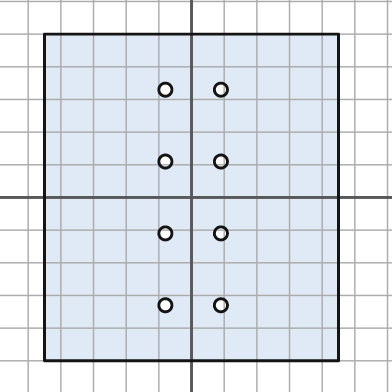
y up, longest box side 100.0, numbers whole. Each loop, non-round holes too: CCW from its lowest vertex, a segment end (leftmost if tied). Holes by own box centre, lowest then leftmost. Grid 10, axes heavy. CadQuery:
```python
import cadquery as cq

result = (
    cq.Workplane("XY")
    .moveTo(-45.0, -50.0)
    .lineTo(45.0, -50.0)
    .lineTo(45.0, 50.0)
    .lineTo(-45.0, 50.0)
    .close()
    .moveTo(-8.0, -33.0)
    .circle(2.0)
    .moveTo(9.0, -33.0)
    .circle(2.0)
    .moveTo(-8.0, -11.0)
    .circle(2.0)
    .moveTo(9.0, -11.0)
    .circle(2.0)
    .moveTo(-8.0, 11.0)
    .circle(2.0)
    .moveTo(9.0, 11.0)
    .circle(2.0)
    .moveTo(-8.0, 33.0)
    .circle(2.0)
    .moveTo(9.0, 33.0)
    .circle(2.0)
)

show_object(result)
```